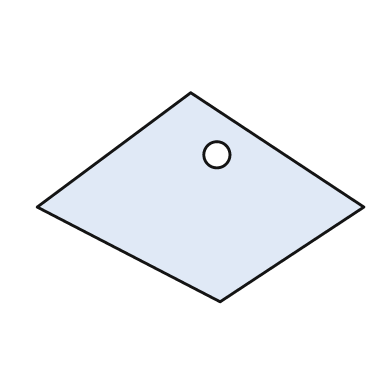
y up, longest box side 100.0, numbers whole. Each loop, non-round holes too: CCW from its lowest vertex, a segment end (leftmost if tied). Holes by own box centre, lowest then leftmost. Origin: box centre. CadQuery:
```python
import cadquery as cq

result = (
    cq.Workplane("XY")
    .moveTo(6.0, -32.0)
    .lineTo(50.0, -3.0)
    .lineTo(-3.0, 32.0)
    .lineTo(-50.0, -3.0)
    .close()
    .moveTo(5.0, 13.0)
    .circle(4.0)
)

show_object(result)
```